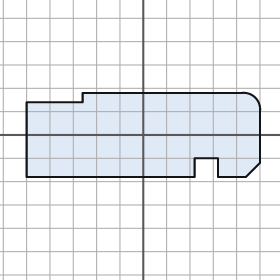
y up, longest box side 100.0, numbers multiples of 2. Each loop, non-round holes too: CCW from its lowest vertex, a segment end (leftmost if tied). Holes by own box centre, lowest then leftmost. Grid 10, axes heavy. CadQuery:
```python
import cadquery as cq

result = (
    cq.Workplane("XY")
    .moveTo(-50.0, -18.0)
    .lineTo(22.0, -18.0)
    .lineTo(22.0, -10.0)
    .lineTo(32.0, -10.0)
    .lineTo(32.0, -18.0)
    .lineTo(44.0, -18.0)
    .lineTo(50.0, -12.0)
    .lineTo(50.0, 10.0)
    .threePointArc((48.0, 16.0), (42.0, 18.0))
    .lineTo(-26.0, 18.0)
    .lineTo(-26.0, 14.0)
    .lineTo(-50.0, 14.0)
    .close()
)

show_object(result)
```